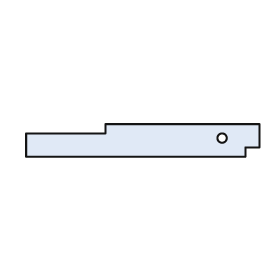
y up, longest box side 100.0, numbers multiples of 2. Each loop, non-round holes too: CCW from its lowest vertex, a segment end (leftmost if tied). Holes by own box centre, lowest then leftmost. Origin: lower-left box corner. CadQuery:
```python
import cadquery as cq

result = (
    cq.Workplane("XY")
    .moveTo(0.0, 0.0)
    .lineTo(94.0, 0.0)
    .lineTo(94.0, 4.0)
    .lineTo(100.0, 4.0)
    .lineTo(100.0, 14.0)
    .lineTo(34.0, 14.0)
    .lineTo(34.0, 10.0)
    .lineTo(0.0, 10.0)
    .close()
    .moveTo(84.0, 8.0)
    .circle(2.0)
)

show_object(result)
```